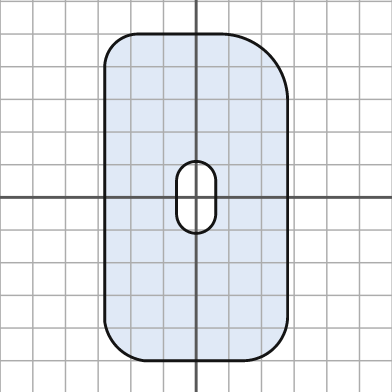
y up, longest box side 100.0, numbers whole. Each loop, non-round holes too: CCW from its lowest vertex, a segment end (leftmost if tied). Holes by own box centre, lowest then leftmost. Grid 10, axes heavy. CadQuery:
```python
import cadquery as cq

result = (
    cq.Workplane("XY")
    .moveTo(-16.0, -50.0)
    .lineTo(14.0, -50.0)
    .threePointArc((24.0, -46.0), (28.0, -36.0))
    .lineTo(28.0, 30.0)
    .threePointArc((22.0, 44.0), (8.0, 50.0))
    .lineTo(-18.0, 50.0)
    .threePointArc((-25.0, 47.0), (-28.0, 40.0))
    .lineTo(-28.0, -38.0)
    .threePointArc((-24.0, -46.0), (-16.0, -50.0))
    .close()
    .moveTo(-6.0, -5.0)
    .threePointArc((0.0, -11.0), (6.0, -5.0))
    .lineTo(6.0, 5.0)
    .threePointArc((0.0, 11.0), (-6.0, 5.0))
    .close()
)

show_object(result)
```